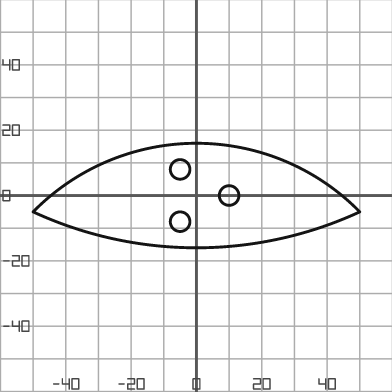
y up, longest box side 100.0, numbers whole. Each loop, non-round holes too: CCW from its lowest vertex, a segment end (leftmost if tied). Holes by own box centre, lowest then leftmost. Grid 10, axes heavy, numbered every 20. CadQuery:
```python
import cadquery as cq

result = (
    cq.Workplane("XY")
    .moveTo(-50.0, -5.0)
    .threePointArc((0.0, -16.0), (50.0, -5.0))
    .threePointArc((0.0, 16.0), (-50.0, -5.0))
    .close()
    .moveTo(-5.0, -8.0)
    .circle(3.0)
    .moveTo(10.0, 0.0)
    .circle(3.0)
    .moveTo(-5.0, 8.0)
    .circle(3.0)
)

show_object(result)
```